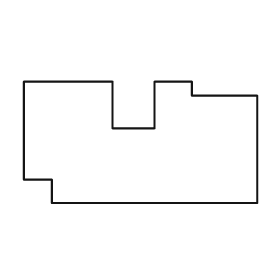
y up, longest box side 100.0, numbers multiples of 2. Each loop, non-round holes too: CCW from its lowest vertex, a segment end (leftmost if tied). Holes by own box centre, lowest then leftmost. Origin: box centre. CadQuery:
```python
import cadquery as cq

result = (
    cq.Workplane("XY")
    .moveTo(-38.0, -26.0)
    .lineTo(50.0, -26.0)
    .lineTo(50.0, 20.0)
    .lineTo(22.0, 20.0)
    .lineTo(22.0, 26.0)
    .lineTo(6.0, 26.0)
    .lineTo(6.0, 6.0)
    .lineTo(-12.0, 6.0)
    .lineTo(-12.0, 26.0)
    .lineTo(-50.0, 26.0)
    .lineTo(-50.0, -16.0)
    .lineTo(-38.0, -16.0)
    .close()
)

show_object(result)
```